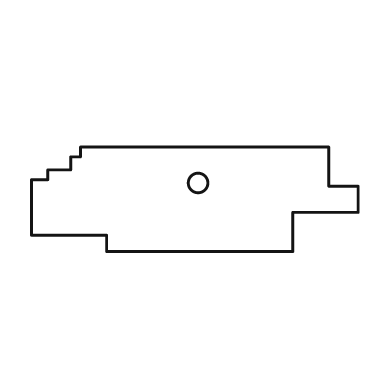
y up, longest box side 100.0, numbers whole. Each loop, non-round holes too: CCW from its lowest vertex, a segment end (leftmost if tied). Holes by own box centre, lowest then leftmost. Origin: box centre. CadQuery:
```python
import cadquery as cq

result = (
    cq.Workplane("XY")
    .moveTo(-27.0, -16.0)
    .lineTo(30.0, -16.0)
    .lineTo(30.0, -4.0)
    .lineTo(50.0, -4.0)
    .lineTo(50.0, 4.0)
    .lineTo(41.0, 4.0)
    .lineTo(41.0, 16.0)
    .lineTo(-35.0, 16.0)
    .lineTo(-35.0, 13.0)
    .lineTo(-38.0, 13.0)
    .lineTo(-38.0, 9.0)
    .lineTo(-45.0, 9.0)
    .lineTo(-45.0, 6.0)
    .lineTo(-50.0, 6.0)
    .lineTo(-50.0, -11.0)
    .lineTo(-27.0, -11.0)
    .close()
    .moveTo(1.0, 5.0)
    .circle(3.0)
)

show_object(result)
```